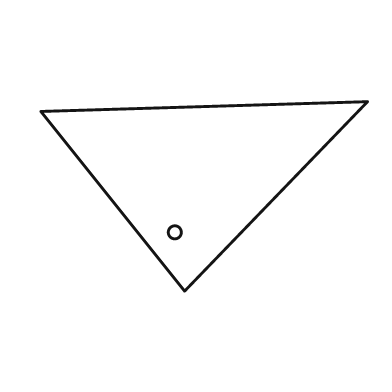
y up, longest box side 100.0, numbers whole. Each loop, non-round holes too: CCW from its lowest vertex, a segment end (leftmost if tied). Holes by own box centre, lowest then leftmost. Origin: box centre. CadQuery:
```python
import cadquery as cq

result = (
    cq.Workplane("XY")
    .moveTo(-6.0, -29.0)
    .lineTo(50.0, 29.0)
    .lineTo(-50.0, 26.0)
    .close()
    .moveTo(-9.0, -11.0)
    .circle(2.0)
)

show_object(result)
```